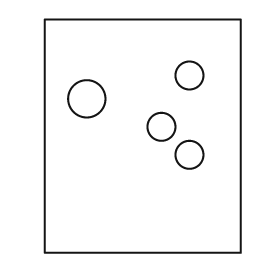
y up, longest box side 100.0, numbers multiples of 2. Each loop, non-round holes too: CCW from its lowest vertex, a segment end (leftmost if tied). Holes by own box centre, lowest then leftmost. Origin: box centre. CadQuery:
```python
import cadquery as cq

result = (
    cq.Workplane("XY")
    .moveTo(-42.0, -50.0)
    .lineTo(42.0, -50.0)
    .lineTo(42.0, 50.0)
    .lineTo(-42.0, 50.0)
    .close()
    .moveTo(20.0, -8.0)
    .circle(6.0)
    .moveTo(8.0, 4.0)
    .circle(6.0)
    .moveTo(-24.0, 16.0)
    .circle(8.0)
    .moveTo(20.0, 26.0)
    .circle(6.0)
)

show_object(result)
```